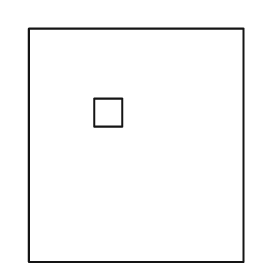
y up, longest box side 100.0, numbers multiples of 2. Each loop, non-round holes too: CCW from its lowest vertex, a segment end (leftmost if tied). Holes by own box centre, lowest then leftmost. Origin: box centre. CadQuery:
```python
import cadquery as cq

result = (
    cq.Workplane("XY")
    .moveTo(-46.0, -50.0)
    .lineTo(46.0, -50.0)
    .lineTo(46.0, 50.0)
    .lineTo(-46.0, 50.0)
    .close()
    .moveTo(-18.0, 8.0)
    .lineTo(-6.0, 8.0)
    .lineTo(-6.0, 20.0)
    .lineTo(-18.0, 20.0)
    .close()
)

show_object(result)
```